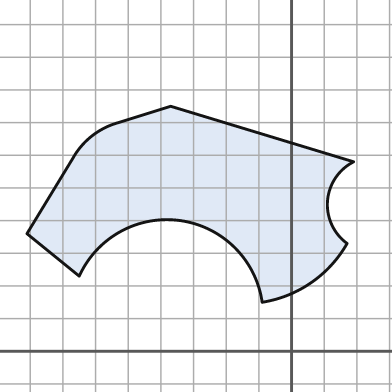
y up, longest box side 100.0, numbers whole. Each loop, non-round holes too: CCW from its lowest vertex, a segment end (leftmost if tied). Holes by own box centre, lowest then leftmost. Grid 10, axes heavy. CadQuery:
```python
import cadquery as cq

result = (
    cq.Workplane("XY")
    .moveTo(-9.0, 15.0)
    .threePointArc((6.0, 21.0), (17.0, 33.0))
    .threePointArc((11.0, 46.0), (19.0, 58.0))
    .lineTo(-37.0, 75.0)
    .lineTo(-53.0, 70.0)
    .threePointArc((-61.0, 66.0), (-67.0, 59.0))
    .lineTo(-81.0, 36.0)
    .lineTo(-65.0, 23.0)
    .threePointArc((-34.0, 40.0), (-9.0, 15.0))
    .close()
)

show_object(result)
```